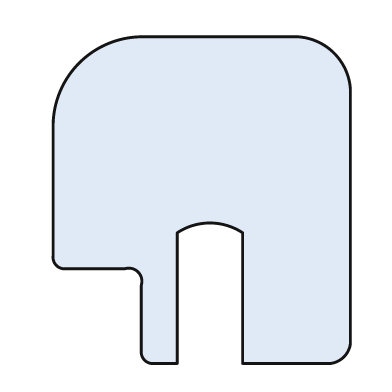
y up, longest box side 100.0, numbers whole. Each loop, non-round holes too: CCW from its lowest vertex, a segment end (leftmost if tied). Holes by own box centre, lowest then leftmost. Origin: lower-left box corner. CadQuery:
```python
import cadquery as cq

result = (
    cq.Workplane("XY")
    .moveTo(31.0, 0.0)
    .lineTo(38.0, 0.0)
    .lineTo(38.0, 40.0)
    .threePointArc((48.0, 43.0), (58.0, 40.0))
    .lineTo(58.0, 0.0)
    .lineTo(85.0, 0.0)
    .threePointArc((89.0, 2.0), (91.0, 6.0))
    .lineTo(91.0, 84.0)
    .threePointArc((86.0, 95.0), (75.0, 100.0))
    .lineTo(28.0, 100.0)
    .threePointArc((8.0, 92.0), (0.0, 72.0))
    .lineTo(0.0, 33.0)
    .threePointArc((1.0, 30.0), (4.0, 29.0))
    .lineTo(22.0, 29.0)
    .threePointArc((26.0, 28.0), (27.0, 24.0))
    .lineTo(27.0, 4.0)
    .threePointArc((28.0, 1.0), (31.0, 0.0))
    .close()
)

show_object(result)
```